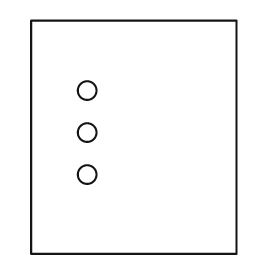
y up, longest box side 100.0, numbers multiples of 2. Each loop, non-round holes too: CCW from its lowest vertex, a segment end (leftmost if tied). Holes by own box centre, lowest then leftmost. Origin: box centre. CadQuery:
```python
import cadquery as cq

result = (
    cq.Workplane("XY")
    .moveTo(-44.0, -50.0)
    .lineTo(44.0, -50.0)
    .lineTo(44.0, 50.0)
    .lineTo(-44.0, 50.0)
    .close()
    .moveTo(-20.0, -16.0)
    .circle(4.0)
    .moveTo(-20.0, 2.0)
    .circle(4.0)
    .moveTo(-20.0, 20.0)
    .circle(4.0)
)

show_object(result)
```